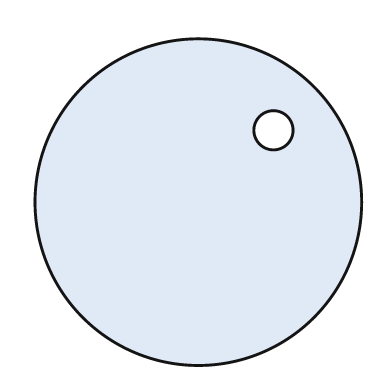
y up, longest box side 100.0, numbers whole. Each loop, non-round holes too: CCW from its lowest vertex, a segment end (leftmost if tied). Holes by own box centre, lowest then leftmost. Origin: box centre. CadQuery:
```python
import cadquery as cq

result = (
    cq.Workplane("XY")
    .moveTo(0.0, 0.0)
    .circle(50.0)
    .moveTo(23.0, 22.0)
    .circle(6.0)
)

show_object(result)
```